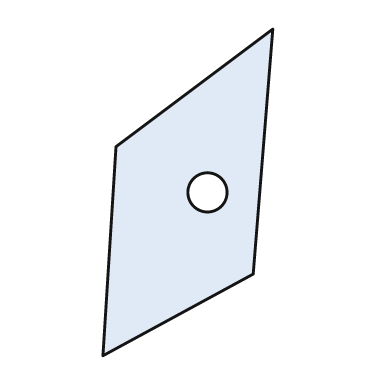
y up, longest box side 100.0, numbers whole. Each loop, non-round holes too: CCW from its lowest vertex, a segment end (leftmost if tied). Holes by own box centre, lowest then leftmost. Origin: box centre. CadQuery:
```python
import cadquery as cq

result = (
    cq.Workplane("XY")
    .moveTo(-26.0, -50.0)
    .lineTo(20.0, -25.0)
    .lineTo(26.0, 50.0)
    .lineTo(-22.0, 14.0)
    .close()
    .moveTo(6.0, 0.0)
    .circle(6.0)
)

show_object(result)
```